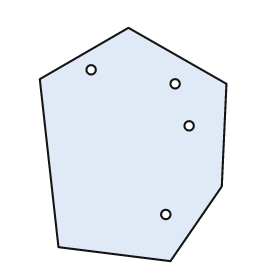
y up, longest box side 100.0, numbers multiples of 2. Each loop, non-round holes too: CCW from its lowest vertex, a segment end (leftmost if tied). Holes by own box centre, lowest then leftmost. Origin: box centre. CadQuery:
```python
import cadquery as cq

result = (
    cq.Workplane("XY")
    .moveTo(16.0, -50.0)
    .lineTo(38.0, -18.0)
    .lineTo(40.0, 26.0)
    .lineTo(-2.0, 50.0)
    .lineTo(-40.0, 28.0)
    .lineTo(-32.0, -44.0)
    .close()
    .moveTo(14.0, -30.0)
    .circle(2.0)
    .moveTo(24.0, 8.0)
    .circle(2.0)
    .moveTo(18.0, 26.0)
    .circle(2.0)
    .moveTo(-18.0, 32.0)
    .circle(2.0)
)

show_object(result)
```